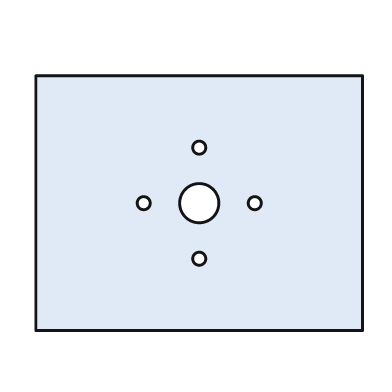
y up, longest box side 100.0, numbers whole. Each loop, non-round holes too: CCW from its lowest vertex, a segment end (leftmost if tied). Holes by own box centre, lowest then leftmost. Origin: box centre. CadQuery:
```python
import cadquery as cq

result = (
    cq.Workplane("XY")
    .moveTo(-50.0, -39.0)
    .lineTo(50.0, -39.0)
    .lineTo(50.0, 39.0)
    .lineTo(-50.0, 39.0)
    .close()
    .moveTo(0.0, -17.0)
    .circle(2.0)
    .moveTo(-17.0, 0.0)
    .circle(2.0)
    .moveTo(0.0, 0.0)
    .circle(6.0)
    .moveTo(17.0, 0.0)
    .circle(2.0)
    .moveTo(0.0, 17.0)
    .circle(2.0)
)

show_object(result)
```